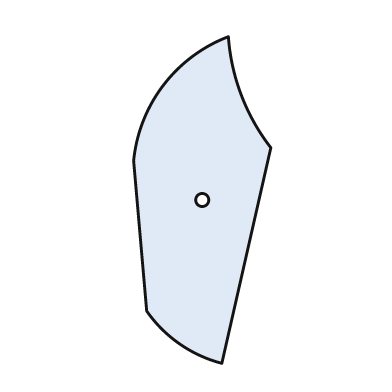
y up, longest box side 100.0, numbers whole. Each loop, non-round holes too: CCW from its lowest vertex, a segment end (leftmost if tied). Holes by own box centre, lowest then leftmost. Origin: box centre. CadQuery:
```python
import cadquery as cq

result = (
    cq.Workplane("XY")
    .moveTo(6.0, -50.0)
    .lineTo(21.0, 16.0)
    .threePointArc((12.0, 32.0), (8.0, 50.0))
    .threePointArc((-12.0, 35.0), (-21.0, 12.0))
    .lineTo(-17.0, -34.0)
    .threePointArc((-7.0, -44.0), (6.0, -50.0))
    .close()
    .moveTo(0.0, 0.0)
    .circle(2.0)
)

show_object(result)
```